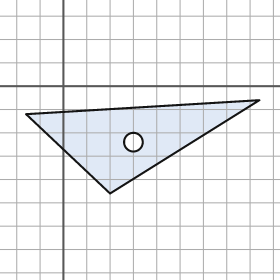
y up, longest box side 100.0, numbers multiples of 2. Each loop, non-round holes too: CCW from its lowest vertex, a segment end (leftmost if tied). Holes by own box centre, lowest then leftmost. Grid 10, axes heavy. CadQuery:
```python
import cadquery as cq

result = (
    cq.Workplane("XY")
    .moveTo(20.0, -46.0)
    .lineTo(84.0, -6.0)
    .lineTo(-16.0, -12.0)
    .close()
    .moveTo(30.0, -24.0)
    .circle(4.0)
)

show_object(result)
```